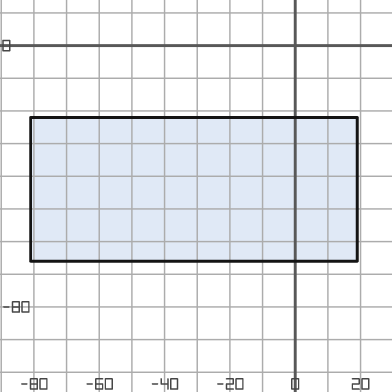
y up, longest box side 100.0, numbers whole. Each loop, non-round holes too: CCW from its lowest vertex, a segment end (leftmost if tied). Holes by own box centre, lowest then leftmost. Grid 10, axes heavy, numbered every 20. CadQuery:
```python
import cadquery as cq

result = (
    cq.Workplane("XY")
    .moveTo(-81.0, -66.0)
    .lineTo(19.0, -66.0)
    .lineTo(19.0, -22.0)
    .lineTo(-81.0, -22.0)
    .close()
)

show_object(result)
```